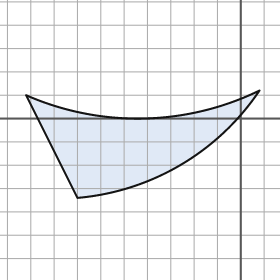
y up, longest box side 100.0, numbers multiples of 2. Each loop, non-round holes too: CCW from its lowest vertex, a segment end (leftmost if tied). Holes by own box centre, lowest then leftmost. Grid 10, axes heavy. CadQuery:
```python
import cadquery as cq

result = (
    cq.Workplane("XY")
    .moveTo(-70.0, -34.0)
    .threePointArc((-26.0, -20.0), (8.0, 12.0))
    .threePointArc((-42.0, 0.0), (-92.0, 10.0))
    .close()
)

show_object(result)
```